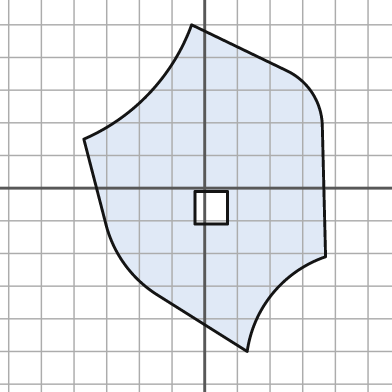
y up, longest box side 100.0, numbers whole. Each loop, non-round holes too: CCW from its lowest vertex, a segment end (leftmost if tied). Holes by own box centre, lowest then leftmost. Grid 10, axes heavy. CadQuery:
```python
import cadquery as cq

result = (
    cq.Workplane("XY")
    .moveTo(13.0, -50.0)
    .threePointArc((21.0, -32.0), (37.0, -21.0))
    .lineTo(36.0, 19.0)
    .threePointArc((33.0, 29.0), (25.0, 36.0))
    .lineTo(-4.0, 50.0)
    .threePointArc((-17.0, 29.0), (-37.0, 15.0))
    .lineTo(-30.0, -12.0)
    .threePointArc((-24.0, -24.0), (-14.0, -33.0))
    .close()
    .moveTo(-3.0, -11.0)
    .lineTo(7.0, -11.0)
    .lineTo(7.0, -1.0)
    .lineTo(-3.0, -1.0)
    .close()
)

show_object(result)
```